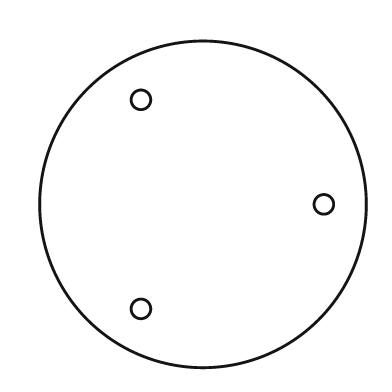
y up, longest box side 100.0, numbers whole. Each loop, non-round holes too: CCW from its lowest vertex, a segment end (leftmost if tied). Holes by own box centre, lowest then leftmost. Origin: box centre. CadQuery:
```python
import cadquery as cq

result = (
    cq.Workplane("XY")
    .moveTo(0.0, 0.0)
    .circle(50.0)
    .moveTo(-19.0, -32.0)
    .circle(3.0)
    .moveTo(37.0, 0.0)
    .circle(3.0)
    .moveTo(-19.0, 32.0)
    .circle(3.0)
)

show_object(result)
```